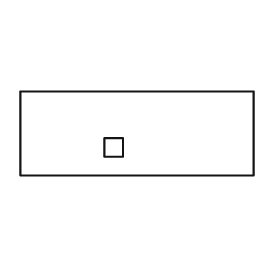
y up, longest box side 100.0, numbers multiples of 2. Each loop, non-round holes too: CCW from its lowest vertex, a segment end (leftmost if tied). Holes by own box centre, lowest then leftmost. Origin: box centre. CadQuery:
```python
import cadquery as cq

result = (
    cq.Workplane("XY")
    .moveTo(-50.0, -18.0)
    .lineTo(50.0, -18.0)
    .lineTo(50.0, 18.0)
    .lineTo(-50.0, 18.0)
    .close()
    .moveTo(-14.0, -10.0)
    .lineTo(-6.0, -10.0)
    .lineTo(-6.0, -2.0)
    .lineTo(-14.0, -2.0)
    .close()
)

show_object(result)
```